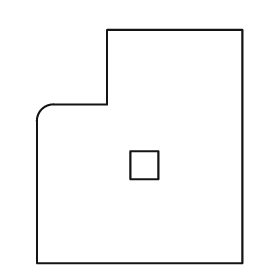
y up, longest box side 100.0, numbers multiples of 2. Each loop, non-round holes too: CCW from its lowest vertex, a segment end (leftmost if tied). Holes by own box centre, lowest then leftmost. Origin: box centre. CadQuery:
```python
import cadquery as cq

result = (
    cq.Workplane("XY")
    .moveTo(-44.0, -50.0)
    .lineTo(44.0, -50.0)
    .lineTo(44.0, 50.0)
    .lineTo(-14.0, 50.0)
    .lineTo(-14.0, 18.0)
    .lineTo(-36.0, 18.0)
    .threePointArc((-42.0, 16.0), (-44.0, 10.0))
    .close()
    .moveTo(-4.0, -14.0)
    .lineTo(8.0, -14.0)
    .lineTo(8.0, -2.0)
    .lineTo(-4.0, -2.0)
    .close()
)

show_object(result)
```